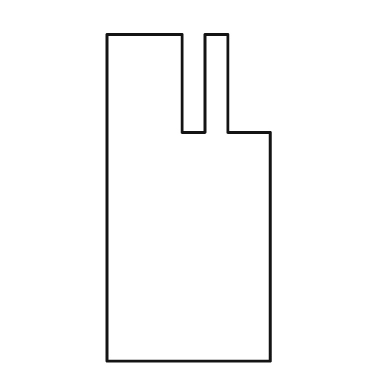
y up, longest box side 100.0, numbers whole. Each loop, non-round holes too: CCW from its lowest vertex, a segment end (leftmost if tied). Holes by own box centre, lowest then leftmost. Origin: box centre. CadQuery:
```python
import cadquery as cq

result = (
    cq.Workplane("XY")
    .moveTo(-25.0, -50.0)
    .lineTo(25.0, -50.0)
    .lineTo(25.0, 20.0)
    .lineTo(12.0, 20.0)
    .lineTo(12.0, 50.0)
    .lineTo(5.0, 50.0)
    .lineTo(5.0, 20.0)
    .lineTo(-2.0, 20.0)
    .lineTo(-2.0, 50.0)
    .lineTo(-25.0, 50.0)
    .close()
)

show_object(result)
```